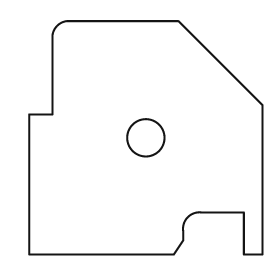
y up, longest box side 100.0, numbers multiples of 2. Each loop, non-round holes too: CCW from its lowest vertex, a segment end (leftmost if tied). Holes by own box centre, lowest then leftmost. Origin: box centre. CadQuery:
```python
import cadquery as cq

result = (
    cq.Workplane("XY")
    .moveTo(-50.0, -50.0)
    .lineTo(12.0, -50.0)
    .lineTo(16.0, -44.0)
    .lineTo(16.0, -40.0)
    .threePointArc((18.0, -34.0), (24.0, -32.0))
    .lineTo(42.0, -32.0)
    .lineTo(42.0, -50.0)
    .lineTo(50.0, -50.0)
    .lineTo(50.0, 14.0)
    .lineTo(14.0, 50.0)
    .lineTo(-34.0, 50.0)
    .threePointArc((-38.0, 48.0), (-40.0, 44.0))
    .lineTo(-40.0, 10.0)
    .lineTo(-50.0, 10.0)
    .close()
    .moveTo(0.0, 0.0)
    .circle(8.0)
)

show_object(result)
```